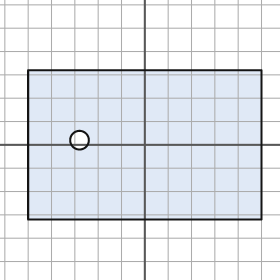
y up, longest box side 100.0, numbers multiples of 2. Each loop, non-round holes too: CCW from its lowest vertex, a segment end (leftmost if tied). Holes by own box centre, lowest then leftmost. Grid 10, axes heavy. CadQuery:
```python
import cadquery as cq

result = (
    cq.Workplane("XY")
    .moveTo(-50.0, -32.0)
    .lineTo(50.0, -32.0)
    .lineTo(50.0, 32.0)
    .lineTo(-50.0, 32.0)
    .close()
    .moveTo(-28.0, 2.0)
    .circle(4.0)
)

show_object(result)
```